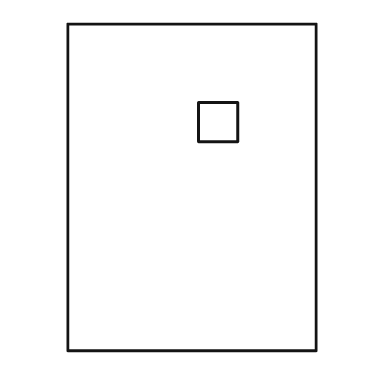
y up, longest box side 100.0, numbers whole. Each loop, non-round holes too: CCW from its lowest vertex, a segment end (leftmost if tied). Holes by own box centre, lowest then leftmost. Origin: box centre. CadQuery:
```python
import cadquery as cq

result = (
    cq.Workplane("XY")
    .moveTo(-38.0, -50.0)
    .lineTo(38.0, -50.0)
    .lineTo(38.0, 50.0)
    .lineTo(-38.0, 50.0)
    .close()
    .moveTo(2.0, 14.0)
    .lineTo(14.0, 14.0)
    .lineTo(14.0, 26.0)
    .lineTo(2.0, 26.0)
    .close()
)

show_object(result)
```